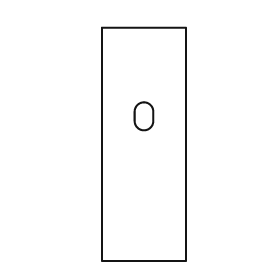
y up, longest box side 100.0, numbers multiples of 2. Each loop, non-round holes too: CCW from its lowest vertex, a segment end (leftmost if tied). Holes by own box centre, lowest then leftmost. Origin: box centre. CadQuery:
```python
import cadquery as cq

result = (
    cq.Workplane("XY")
    .moveTo(-18.0, -50.0)
    .lineTo(18.0, -50.0)
    .lineTo(18.0, 50.0)
    .lineTo(-18.0, 50.0)
    .close()
    .moveTo(-4.0, 10.0)
    .threePointArc((0.0, 6.0), (4.0, 10.0))
    .lineTo(4.0, 14.0)
    .threePointArc((0.0, 18.0), (-4.0, 14.0))
    .close()
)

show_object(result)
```